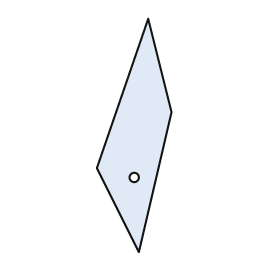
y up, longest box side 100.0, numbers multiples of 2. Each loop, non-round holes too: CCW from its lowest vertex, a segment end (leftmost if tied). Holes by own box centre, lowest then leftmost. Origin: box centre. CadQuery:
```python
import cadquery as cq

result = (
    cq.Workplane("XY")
    .moveTo(2.0, -50.0)
    .lineTo(16.0, 10.0)
    .lineTo(6.0, 50.0)
    .lineTo(-16.0, -14.0)
    .close()
    .moveTo(0.0, -18.0)
    .circle(2.0)
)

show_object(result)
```